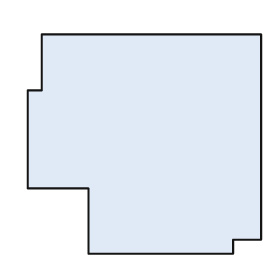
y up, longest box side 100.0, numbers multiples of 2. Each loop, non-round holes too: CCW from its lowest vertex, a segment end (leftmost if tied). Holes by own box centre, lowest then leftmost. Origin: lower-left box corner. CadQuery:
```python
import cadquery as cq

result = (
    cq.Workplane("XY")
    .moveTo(26.0, 0.0)
    .lineTo(88.0, 0.0)
    .lineTo(88.0, 6.0)
    .lineTo(100.0, 6.0)
    .lineTo(100.0, 94.0)
    .lineTo(6.0, 94.0)
    .lineTo(6.0, 70.0)
    .lineTo(0.0, 70.0)
    .lineTo(0.0, 28.0)
    .lineTo(26.0, 28.0)
    .close()
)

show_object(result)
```